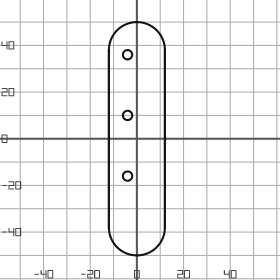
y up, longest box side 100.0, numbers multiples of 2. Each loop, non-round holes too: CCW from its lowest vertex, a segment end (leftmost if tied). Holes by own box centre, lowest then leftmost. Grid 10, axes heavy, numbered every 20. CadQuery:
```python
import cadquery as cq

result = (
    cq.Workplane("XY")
    .moveTo(-12.0, -38.0)
    .threePointArc((0.0, -50.0), (12.0, -38.0))
    .lineTo(12.0, 38.0)
    .threePointArc((0.0, 50.0), (-12.0, 38.0))
    .close()
    .moveTo(-4.0, -16.0)
    .circle(2.0)
    .moveTo(-4.0, 10.0)
    .circle(2.0)
    .moveTo(-4.0, 36.0)
    .circle(2.0)
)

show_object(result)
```